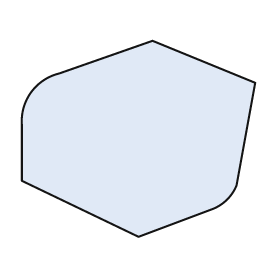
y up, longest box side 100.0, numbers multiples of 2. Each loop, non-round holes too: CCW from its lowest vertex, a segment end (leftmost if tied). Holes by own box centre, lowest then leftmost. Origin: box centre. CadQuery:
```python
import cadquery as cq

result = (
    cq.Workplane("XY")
    .moveTo(0.0, -42.0)
    .lineTo(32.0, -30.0)
    .threePointArc((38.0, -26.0), (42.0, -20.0))
    .lineTo(50.0, 24.0)
    .lineTo(6.0, 42.0)
    .lineTo(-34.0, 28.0)
    .threePointArc((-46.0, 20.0), (-50.0, 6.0))
    .lineTo(-50.0, -18.0)
    .close()
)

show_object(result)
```